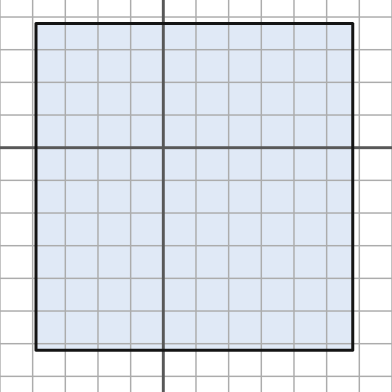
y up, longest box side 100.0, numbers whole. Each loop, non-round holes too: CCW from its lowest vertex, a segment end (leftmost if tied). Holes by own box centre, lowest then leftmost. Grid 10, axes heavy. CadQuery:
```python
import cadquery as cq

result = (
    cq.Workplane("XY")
    .moveTo(-39.0, -62.0)
    .lineTo(58.0, -62.0)
    .lineTo(58.0, 38.0)
    .lineTo(-39.0, 38.0)
    .close()
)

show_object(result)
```